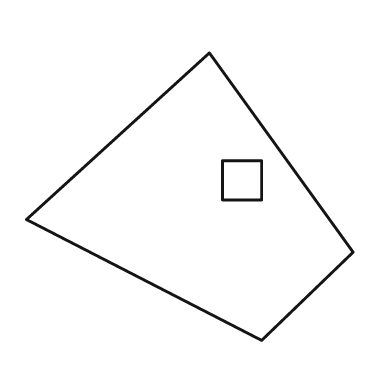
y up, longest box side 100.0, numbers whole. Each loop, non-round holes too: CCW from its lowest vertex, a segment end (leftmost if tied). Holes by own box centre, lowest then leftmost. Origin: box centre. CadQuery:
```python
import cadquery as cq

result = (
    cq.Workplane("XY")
    .moveTo(22.0, -44.0)
    .lineTo(50.0, -17.0)
    .lineTo(6.0, 44.0)
    .lineTo(-50.0, -7.0)
    .close()
    .moveTo(10.0, -1.0)
    .lineTo(22.0, -1.0)
    .lineTo(22.0, 11.0)
    .lineTo(10.0, 11.0)
    .close()
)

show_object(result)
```